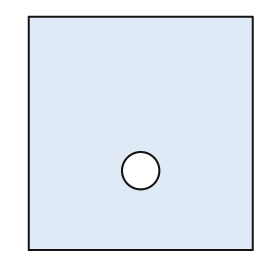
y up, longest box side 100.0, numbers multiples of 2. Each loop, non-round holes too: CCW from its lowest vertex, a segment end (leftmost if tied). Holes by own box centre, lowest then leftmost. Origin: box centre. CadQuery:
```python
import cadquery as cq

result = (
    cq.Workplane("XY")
    .moveTo(-48.0, -50.0)
    .lineTo(48.0, -50.0)
    .lineTo(48.0, 50.0)
    .lineTo(-48.0, 50.0)
    .close()
    .moveTo(0.0, -16.0)
    .circle(8.0)
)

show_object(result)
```